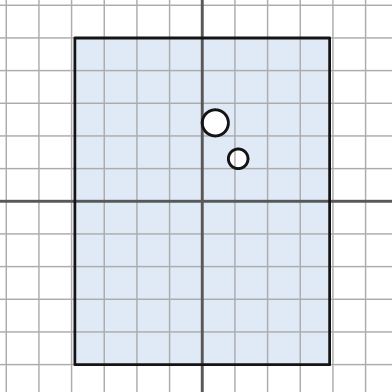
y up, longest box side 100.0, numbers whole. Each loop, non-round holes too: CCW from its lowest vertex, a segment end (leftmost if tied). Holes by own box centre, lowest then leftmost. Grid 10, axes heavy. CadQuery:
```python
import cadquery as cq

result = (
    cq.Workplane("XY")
    .moveTo(-39.0, -50.0)
    .lineTo(39.0, -50.0)
    .lineTo(39.0, 50.0)
    .lineTo(-39.0, 50.0)
    .close()
    .moveTo(11.0, 13.0)
    .circle(3.0)
    .moveTo(4.0, 24.0)
    .circle(4.0)
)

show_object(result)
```